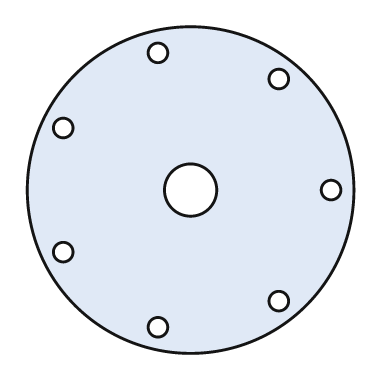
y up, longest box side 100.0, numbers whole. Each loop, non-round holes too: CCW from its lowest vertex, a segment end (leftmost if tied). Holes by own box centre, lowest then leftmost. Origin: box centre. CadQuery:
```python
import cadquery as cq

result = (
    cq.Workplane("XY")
    .moveTo(0.0, 0.0)
    .circle(50.0)
    .moveTo(-10.0, -42.0)
    .circle(3.0)
    .moveTo(27.0, -34.0)
    .circle(3.0)
    .moveTo(-39.0, -19.0)
    .circle(3.0)
    .moveTo(0.0, 0.0)
    .circle(8.0)
    .moveTo(43.0, 0.0)
    .circle(3.0)
    .moveTo(-39.0, 19.0)
    .circle(3.0)
    .moveTo(27.0, 34.0)
    .circle(3.0)
    .moveTo(-10.0, 42.0)
    .circle(3.0)
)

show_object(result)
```